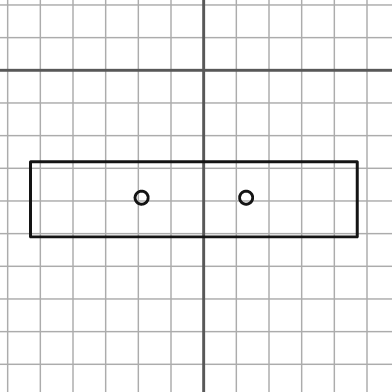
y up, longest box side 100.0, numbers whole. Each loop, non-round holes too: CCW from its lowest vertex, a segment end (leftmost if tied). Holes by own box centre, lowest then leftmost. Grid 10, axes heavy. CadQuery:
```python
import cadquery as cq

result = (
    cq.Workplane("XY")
    .moveTo(-53.0, -51.0)
    .lineTo(47.0, -51.0)
    .lineTo(47.0, -28.0)
    .lineTo(-53.0, -28.0)
    .close()
    .moveTo(-19.0, -39.0)
    .circle(2.0)
    .moveTo(13.0, -39.0)
    .circle(2.0)
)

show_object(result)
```